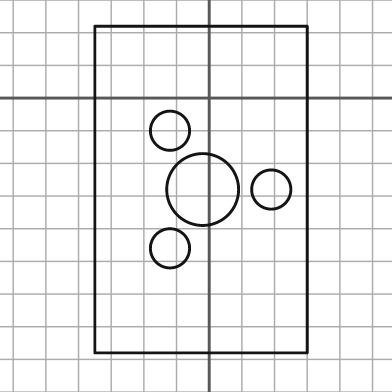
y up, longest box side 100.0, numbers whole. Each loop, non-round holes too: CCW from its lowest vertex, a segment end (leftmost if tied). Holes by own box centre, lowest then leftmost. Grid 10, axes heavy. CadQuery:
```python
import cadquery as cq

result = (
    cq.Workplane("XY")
    .moveTo(-35.0, -78.0)
    .lineTo(30.0, -78.0)
    .lineTo(30.0, 22.0)
    .lineTo(-35.0, 22.0)
    .close()
    .moveTo(-12.0, -46.0)
    .circle(6.0)
    .moveTo(-2.0, -28.0)
    .circle(11.0)
    .moveTo(19.0, -28.0)
    .circle(6.0)
    .moveTo(-12.0, -10.0)
    .circle(6.0)
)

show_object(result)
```